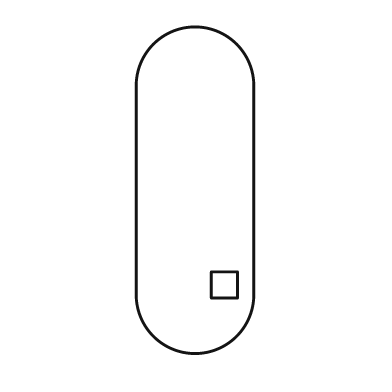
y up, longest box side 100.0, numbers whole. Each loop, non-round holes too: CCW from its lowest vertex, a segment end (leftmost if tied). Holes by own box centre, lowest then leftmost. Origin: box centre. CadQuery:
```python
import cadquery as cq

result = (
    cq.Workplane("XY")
    .moveTo(-18.0, -32.0)
    .threePointArc((0.0, -50.0), (18.0, -32.0))
    .lineTo(18.0, 32.0)
    .threePointArc((0.0, 50.0), (-18.0, 32.0))
    .close()
    .moveTo(5.0, -33.0)
    .lineTo(13.0, -33.0)
    .lineTo(13.0, -25.0)
    .lineTo(5.0, -25.0)
    .close()
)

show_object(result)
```